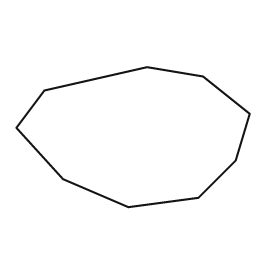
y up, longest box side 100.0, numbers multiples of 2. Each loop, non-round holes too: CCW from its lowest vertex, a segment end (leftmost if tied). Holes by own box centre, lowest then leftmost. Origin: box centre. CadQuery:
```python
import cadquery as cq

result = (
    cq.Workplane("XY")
    .moveTo(-2.0, -30.0)
    .lineTo(28.0, -26.0)
    .lineTo(44.0, -10.0)
    .lineTo(50.0, 10.0)
    .lineTo(30.0, 26.0)
    .lineTo(6.0, 30.0)
    .lineTo(-38.0, 20.0)
    .lineTo(-50.0, 4.0)
    .lineTo(-30.0, -18.0)
    .close()
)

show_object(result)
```